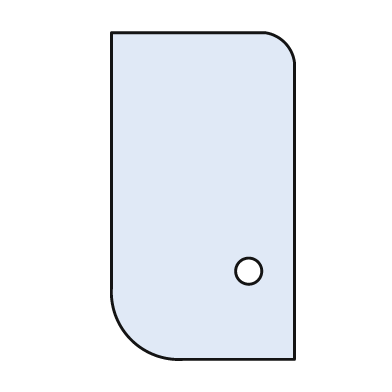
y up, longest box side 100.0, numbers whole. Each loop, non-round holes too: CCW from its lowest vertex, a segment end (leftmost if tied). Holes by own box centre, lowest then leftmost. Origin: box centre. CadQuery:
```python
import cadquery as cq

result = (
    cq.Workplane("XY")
    .moveTo(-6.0, -50.0)
    .lineTo(28.0, -50.0)
    .lineTo(28.0, 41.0)
    .threePointArc((25.0, 47.0), (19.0, 50.0))
    .lineTo(-28.0, 50.0)
    .lineTo(-28.0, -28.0)
    .threePointArc((-22.0, -44.0), (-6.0, -50.0))
    .close()
    .moveTo(14.0, -23.0)
    .circle(4.0)
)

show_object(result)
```